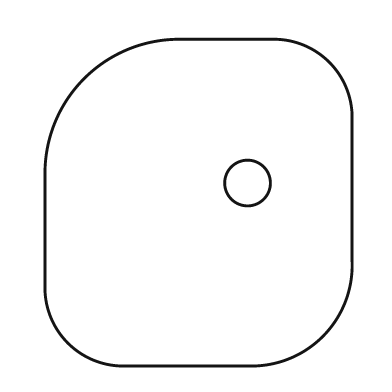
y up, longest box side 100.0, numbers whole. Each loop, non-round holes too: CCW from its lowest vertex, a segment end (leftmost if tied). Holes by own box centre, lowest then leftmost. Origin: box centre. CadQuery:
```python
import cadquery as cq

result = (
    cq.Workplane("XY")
    .moveTo(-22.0, -50.0)
    .lineTo(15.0, -50.0)
    .threePointArc((38.0, -41.0), (47.0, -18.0))
    .lineTo(47.0, 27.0)
    .threePointArc((40.0, 43.0), (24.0, 50.0))
    .lineTo(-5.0, 50.0)
    .threePointArc((-35.0, 38.0), (-47.0, 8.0))
    .lineTo(-47.0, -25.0)
    .threePointArc((-40.0, -43.0), (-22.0, -50.0))
    .close()
    .moveTo(15.0, 6.0)
    .circle(7.0)
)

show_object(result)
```